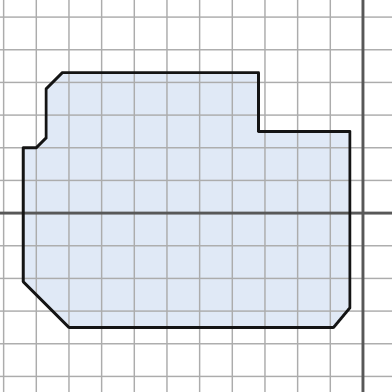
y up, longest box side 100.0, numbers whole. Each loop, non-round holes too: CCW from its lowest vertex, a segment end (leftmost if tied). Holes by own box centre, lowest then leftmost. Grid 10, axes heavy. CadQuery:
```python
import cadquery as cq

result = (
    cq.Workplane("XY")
    .moveTo(-90.0, -35.0)
    .lineTo(-9.0, -35.0)
    .lineTo(-4.0, -29.0)
    .lineTo(-4.0, 25.0)
    .lineTo(-32.0, 25.0)
    .lineTo(-32.0, 43.0)
    .lineTo(-92.0, 43.0)
    .lineTo(-97.0, 38.0)
    .lineTo(-97.0, 23.0)
    .lineTo(-100.0, 20.0)
    .lineTo(-104.0, 20.0)
    .lineTo(-104.0, -21.0)
    .close()
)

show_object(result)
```